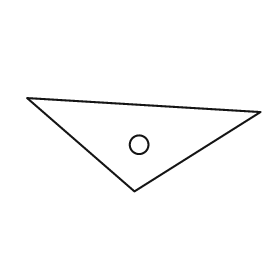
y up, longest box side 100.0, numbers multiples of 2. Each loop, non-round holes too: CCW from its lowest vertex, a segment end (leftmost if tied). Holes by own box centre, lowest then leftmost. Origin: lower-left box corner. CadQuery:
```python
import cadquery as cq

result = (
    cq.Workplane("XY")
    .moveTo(46.0, 0.0)
    .lineTo(100.0, 34.0)
    .lineTo(0.0, 40.0)
    .close()
    .moveTo(48.0, 20.0)
    .circle(4.0)
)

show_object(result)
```